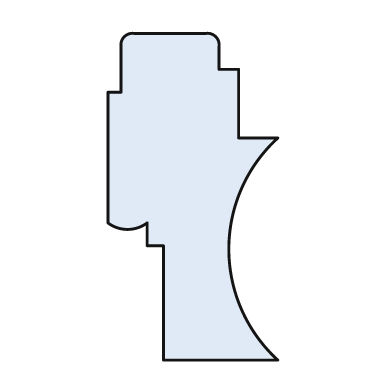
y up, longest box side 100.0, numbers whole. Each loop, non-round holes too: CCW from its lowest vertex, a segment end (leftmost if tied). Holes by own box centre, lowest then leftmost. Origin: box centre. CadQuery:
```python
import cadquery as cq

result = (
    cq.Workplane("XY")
    .moveTo(-9.0, -50.0)
    .lineTo(26.0, -50.0)
    .threePointArc((11.0, -16.0), (26.0, 18.0))
    .lineTo(14.0, 18.0)
    .lineTo(14.0, 39.0)
    .lineTo(8.0, 39.0)
    .lineTo(8.0, 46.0)
    .threePointArc((7.0, 49.0), (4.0, 50.0))
    .lineTo(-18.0, 50.0)
    .threePointArc((-21.0, 49.0), (-22.0, 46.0))
    .lineTo(-22.0, 32.0)
    .lineTo(-26.0, 32.0)
    .lineTo(-26.0, -8.0)
    .threePointArc((-20.0, -10.0), (-14.0, -8.0))
    .lineTo(-14.0, -15.0)
    .lineTo(-9.0, -15.0)
    .close()
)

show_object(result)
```